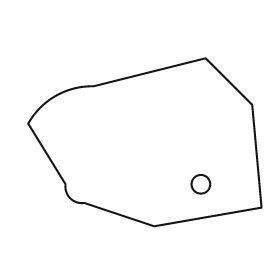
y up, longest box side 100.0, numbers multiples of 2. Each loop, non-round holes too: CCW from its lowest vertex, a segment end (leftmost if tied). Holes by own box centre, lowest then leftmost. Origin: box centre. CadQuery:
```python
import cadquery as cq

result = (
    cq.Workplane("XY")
    .moveTo(4.0, -36.0)
    .lineTo(50.0, -28.0)
    .lineTo(46.0, 16.0)
    .lineTo(26.0, 36.0)
    .lineTo(-22.0, 24.0)
    .threePointArc((-38.0, 20.0), (-50.0, 8.0))
    .lineTo(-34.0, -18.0)
    .threePointArc((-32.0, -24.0), (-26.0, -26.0))
    .close()
    .moveTo(24.0, -18.0)
    .circle(4.0)
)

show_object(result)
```